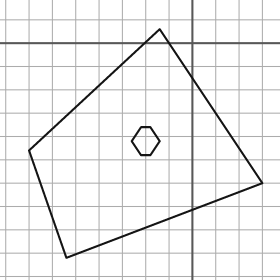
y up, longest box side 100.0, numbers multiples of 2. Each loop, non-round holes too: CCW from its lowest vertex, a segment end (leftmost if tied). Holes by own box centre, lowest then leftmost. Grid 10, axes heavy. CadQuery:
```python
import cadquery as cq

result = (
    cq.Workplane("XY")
    .moveTo(-54.0, -92.0)
    .lineTo(30.0, -60.0)
    .lineTo(-14.0, 6.0)
    .lineTo(-70.0, -46.0)
    .close()
    .moveTo(-22.0, -48.0)
    .lineTo(-18.0, -48.0)
    .lineTo(-14.0, -42.0)
    .lineTo(-18.0, -36.0)
    .lineTo(-22.0, -36.0)
    .lineTo(-26.0, -42.0)
    .close()
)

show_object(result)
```